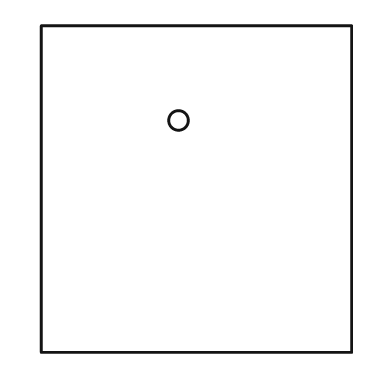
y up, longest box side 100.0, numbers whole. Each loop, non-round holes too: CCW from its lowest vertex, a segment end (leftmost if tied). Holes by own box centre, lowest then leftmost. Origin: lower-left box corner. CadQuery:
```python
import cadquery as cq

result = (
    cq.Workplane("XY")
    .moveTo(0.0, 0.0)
    .lineTo(95.0, 0.0)
    .lineTo(95.0, 100.0)
    .lineTo(0.0, 100.0)
    .close()
    .moveTo(42.0, 71.0)
    .circle(3.0)
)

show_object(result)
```